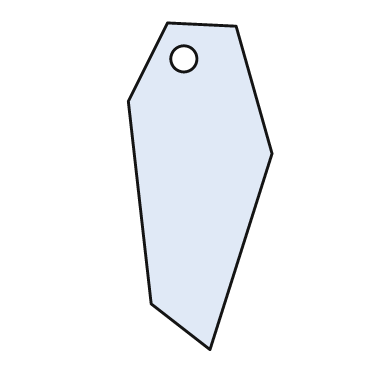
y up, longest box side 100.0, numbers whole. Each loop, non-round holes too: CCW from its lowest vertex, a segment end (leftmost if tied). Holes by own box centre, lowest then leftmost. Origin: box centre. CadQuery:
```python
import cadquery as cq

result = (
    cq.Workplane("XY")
    .moveTo(3.0, -50.0)
    .lineTo(22.0, 10.0)
    .lineTo(11.0, 49.0)
    .lineTo(-10.0, 50.0)
    .lineTo(-22.0, 26.0)
    .lineTo(-15.0, -36.0)
    .close()
    .moveTo(-5.0, 39.0)
    .circle(4.0)
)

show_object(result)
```